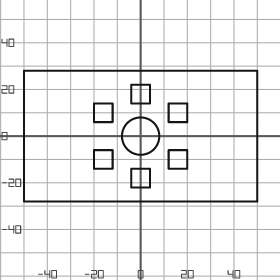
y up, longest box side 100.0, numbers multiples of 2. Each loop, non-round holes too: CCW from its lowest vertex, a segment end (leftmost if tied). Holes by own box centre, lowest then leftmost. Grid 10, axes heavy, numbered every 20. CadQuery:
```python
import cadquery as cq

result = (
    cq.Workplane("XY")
    .moveTo(-50.0, -28.0)
    .lineTo(50.0, -28.0)
    .lineTo(50.0, 28.0)
    .lineTo(-50.0, 28.0)
    .close()
    .moveTo(-4.0, -22.0)
    .lineTo(4.0, -22.0)
    .lineTo(4.0, -14.0)
    .lineTo(-4.0, -14.0)
    .close()
    .moveTo(-20.0, -14.0)
    .lineTo(-12.0, -14.0)
    .lineTo(-12.0, -6.0)
    .lineTo(-20.0, -6.0)
    .close()
    .moveTo(12.0, -14.0)
    .lineTo(20.0, -14.0)
    .lineTo(20.0, -6.0)
    .lineTo(12.0, -6.0)
    .close()
    .moveTo(0.0, 0.0)
    .circle(8.0)
    .moveTo(-20.0, 6.0)
    .lineTo(-12.0, 6.0)
    .lineTo(-12.0, 14.0)
    .lineTo(-20.0, 14.0)
    .close()
    .moveTo(12.0, 6.0)
    .lineTo(20.0, 6.0)
    .lineTo(20.0, 14.0)
    .lineTo(12.0, 14.0)
    .close()
    .moveTo(-4.0, 14.0)
    .lineTo(4.0, 14.0)
    .lineTo(4.0, 22.0)
    .lineTo(-4.0, 22.0)
    .close()
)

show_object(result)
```